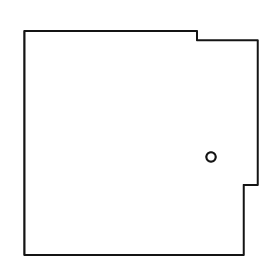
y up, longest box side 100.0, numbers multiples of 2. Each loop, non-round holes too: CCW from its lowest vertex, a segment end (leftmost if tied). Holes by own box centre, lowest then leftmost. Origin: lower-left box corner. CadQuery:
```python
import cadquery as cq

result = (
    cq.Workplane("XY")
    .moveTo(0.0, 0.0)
    .lineTo(94.0, 0.0)
    .lineTo(94.0, 30.0)
    .lineTo(100.0, 30.0)
    .lineTo(100.0, 92.0)
    .lineTo(74.0, 92.0)
    .lineTo(74.0, 96.0)
    .lineTo(0.0, 96.0)
    .close()
    .moveTo(80.0, 42.0)
    .circle(2.0)
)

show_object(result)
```